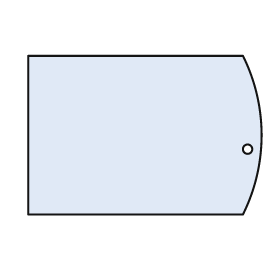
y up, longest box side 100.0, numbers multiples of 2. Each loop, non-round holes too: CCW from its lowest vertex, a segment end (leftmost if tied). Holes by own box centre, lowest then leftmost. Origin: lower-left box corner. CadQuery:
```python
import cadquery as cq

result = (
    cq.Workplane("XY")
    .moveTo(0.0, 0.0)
    .lineTo(92.0, 0.0)
    .threePointArc((100.0, 34.0), (92.0, 68.0))
    .lineTo(0.0, 68.0)
    .close()
    .moveTo(94.0, 28.0)
    .circle(2.0)
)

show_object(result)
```